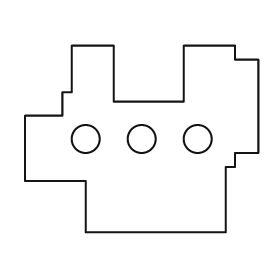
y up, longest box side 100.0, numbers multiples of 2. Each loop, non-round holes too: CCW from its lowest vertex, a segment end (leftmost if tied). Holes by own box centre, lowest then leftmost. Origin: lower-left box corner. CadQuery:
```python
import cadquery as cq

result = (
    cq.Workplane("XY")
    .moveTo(26.0, 0.0)
    .lineTo(86.0, 0.0)
    .lineTo(86.0, 28.0)
    .lineTo(90.0, 28.0)
    .lineTo(90.0, 34.0)
    .lineTo(100.0, 34.0)
    .lineTo(100.0, 74.0)
    .lineTo(90.0, 74.0)
    .lineTo(90.0, 80.0)
    .lineTo(68.0, 80.0)
    .lineTo(68.0, 56.0)
    .lineTo(38.0, 56.0)
    .lineTo(38.0, 80.0)
    .lineTo(20.0, 80.0)
    .lineTo(20.0, 60.0)
    .lineTo(16.0, 60.0)
    .lineTo(16.0, 50.0)
    .lineTo(0.0, 50.0)
    .lineTo(0.0, 22.0)
    .lineTo(26.0, 22.0)
    .close()
    .moveTo(26.0, 40.0)
    .circle(6.0)
    .moveTo(50.0, 40.0)
    .circle(6.0)
    .moveTo(74.0, 40.0)
    .circle(6.0)
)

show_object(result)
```